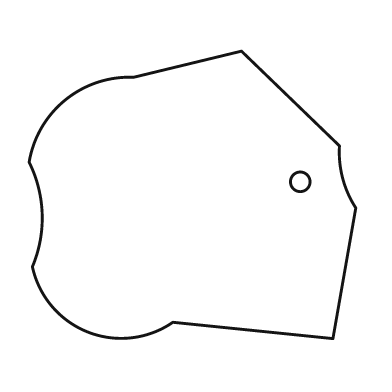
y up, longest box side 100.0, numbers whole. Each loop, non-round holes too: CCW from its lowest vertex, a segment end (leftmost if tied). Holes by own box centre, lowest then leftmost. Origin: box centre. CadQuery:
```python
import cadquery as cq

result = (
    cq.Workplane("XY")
    .moveTo(43.0, -44.0)
    .lineTo(50.0, -4.0)
    .threePointArc((46.0, 5.0), (45.0, 15.0))
    .lineTo(15.0, 44.0)
    .lineTo(-18.0, 36.0)
    .threePointArc((-39.0, 29.0), (-50.0, 10.0))
    .threePointArc((-46.0, -6.0), (-49.0, -22.0))
    .threePointArc((-32.0, -42.0), (-6.0, -39.0))
    .close()
    .moveTo(33.0, 4.0)
    .circle(3.0)
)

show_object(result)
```